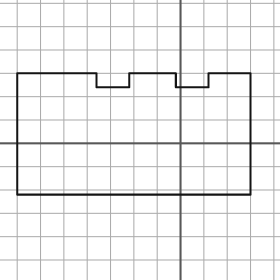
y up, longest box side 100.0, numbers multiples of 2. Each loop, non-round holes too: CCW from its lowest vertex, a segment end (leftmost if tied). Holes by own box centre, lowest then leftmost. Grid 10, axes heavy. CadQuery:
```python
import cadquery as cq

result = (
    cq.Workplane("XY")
    .moveTo(-70.0, -22.0)
    .lineTo(30.0, -22.0)
    .lineTo(30.0, 30.0)
    .lineTo(12.0, 30.0)
    .lineTo(12.0, 24.0)
    .lineTo(-2.0, 24.0)
    .lineTo(-2.0, 30.0)
    .lineTo(-22.0, 30.0)
    .lineTo(-22.0, 24.0)
    .lineTo(-36.0, 24.0)
    .lineTo(-36.0, 30.0)
    .lineTo(-70.0, 30.0)
    .close()
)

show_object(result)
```